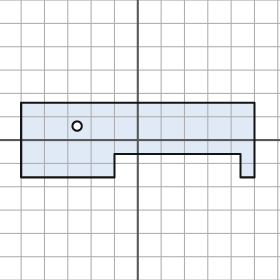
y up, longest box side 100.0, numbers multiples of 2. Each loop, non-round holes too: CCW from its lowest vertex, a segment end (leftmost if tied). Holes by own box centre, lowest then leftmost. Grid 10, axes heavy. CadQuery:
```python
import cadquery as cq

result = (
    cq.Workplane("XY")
    .moveTo(-50.0, -16.0)
    .lineTo(-10.0, -16.0)
    .lineTo(-10.0, -6.0)
    .lineTo(44.0, -6.0)
    .lineTo(44.0, -16.0)
    .lineTo(50.0, -16.0)
    .lineTo(50.0, 16.0)
    .lineTo(-50.0, 16.0)
    .close()
    .moveTo(-26.0, 6.0)
    .circle(2.0)
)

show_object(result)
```